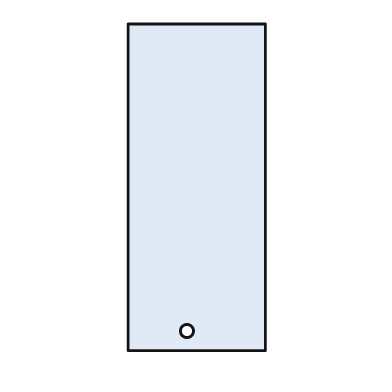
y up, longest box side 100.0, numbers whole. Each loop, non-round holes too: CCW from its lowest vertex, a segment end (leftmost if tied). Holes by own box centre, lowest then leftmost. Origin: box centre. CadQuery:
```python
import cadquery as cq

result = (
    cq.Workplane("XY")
    .moveTo(-21.0, -50.0)
    .lineTo(21.0, -50.0)
    .lineTo(21.0, 50.0)
    .lineTo(-21.0, 50.0)
    .close()
    .moveTo(-3.0, -44.0)
    .circle(2.0)
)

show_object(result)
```